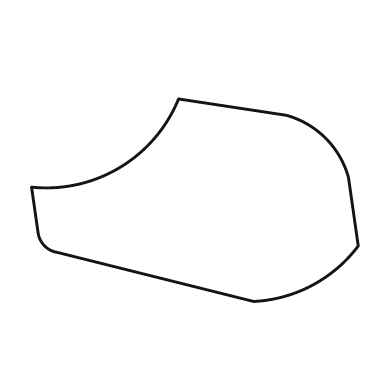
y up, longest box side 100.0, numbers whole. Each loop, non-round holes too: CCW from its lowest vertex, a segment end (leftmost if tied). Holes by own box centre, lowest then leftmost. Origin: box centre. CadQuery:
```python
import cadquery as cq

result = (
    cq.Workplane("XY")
    .moveTo(18.0, -31.0)
    .threePointArc((36.0, -26.0), (50.0, -14.0))
    .lineTo(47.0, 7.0)
    .threePointArc((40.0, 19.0), (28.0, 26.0))
    .lineTo(-5.0, 31.0)
    .threePointArc((-23.0, 10.0), (-50.0, 4.0))
    .lineTo(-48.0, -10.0)
    .threePointArc((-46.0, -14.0), (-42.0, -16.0))
    .close()
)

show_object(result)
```